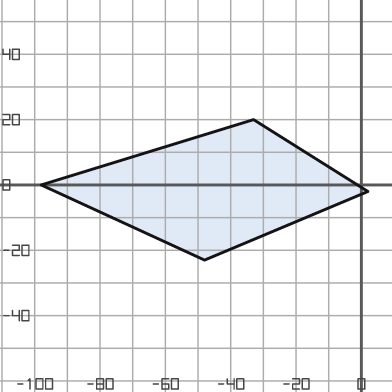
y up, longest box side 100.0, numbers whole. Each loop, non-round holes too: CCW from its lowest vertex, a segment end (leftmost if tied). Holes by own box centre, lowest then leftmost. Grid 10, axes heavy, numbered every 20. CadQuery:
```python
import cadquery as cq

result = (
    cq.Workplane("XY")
    .moveTo(-48.0, -23.0)
    .lineTo(2.0, -2.0)
    .lineTo(-33.0, 20.0)
    .lineTo(-98.0, 0.0)
    .close()
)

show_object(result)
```